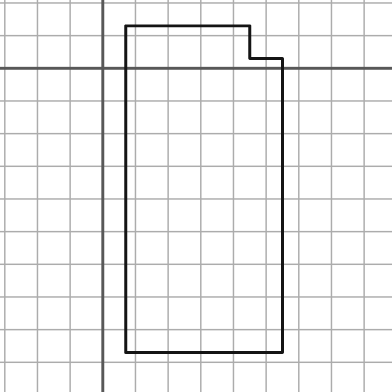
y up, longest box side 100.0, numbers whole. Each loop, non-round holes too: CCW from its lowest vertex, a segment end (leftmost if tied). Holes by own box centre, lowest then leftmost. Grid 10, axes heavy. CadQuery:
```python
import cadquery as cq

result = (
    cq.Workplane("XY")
    .moveTo(7.0, -87.0)
    .lineTo(55.0, -87.0)
    .lineTo(55.0, 3.0)
    .lineTo(45.0, 3.0)
    .lineTo(45.0, 13.0)
    .lineTo(7.0, 13.0)
    .close()
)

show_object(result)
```